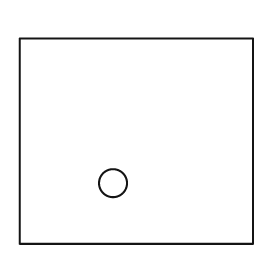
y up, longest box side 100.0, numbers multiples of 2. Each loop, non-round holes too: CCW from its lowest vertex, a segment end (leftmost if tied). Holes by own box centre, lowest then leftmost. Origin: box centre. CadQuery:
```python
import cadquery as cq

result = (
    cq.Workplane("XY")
    .moveTo(-50.0, -44.0)
    .lineTo(50.0, -44.0)
    .lineTo(50.0, 44.0)
    .lineTo(-50.0, 44.0)
    .close()
    .moveTo(-10.0, -18.0)
    .circle(6.0)
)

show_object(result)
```